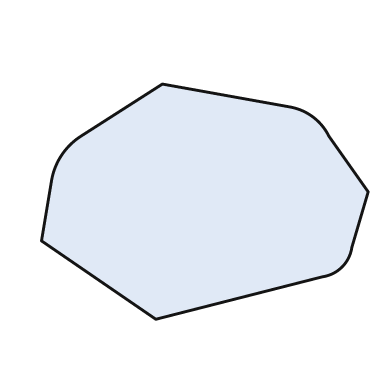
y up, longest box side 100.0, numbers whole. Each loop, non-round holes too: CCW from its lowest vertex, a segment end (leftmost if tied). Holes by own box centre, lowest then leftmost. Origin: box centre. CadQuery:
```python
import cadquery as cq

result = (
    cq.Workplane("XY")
    .moveTo(-15.0, -36.0)
    .lineTo(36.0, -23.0)
    .threePointArc((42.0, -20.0), (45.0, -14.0))
    .lineTo(50.0, 3.0)
    .lineTo(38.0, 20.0)
    .threePointArc((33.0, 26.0), (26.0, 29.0))
    .lineTo(-13.0, 36.0)
    .lineTo(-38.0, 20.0)
    .threePointArc((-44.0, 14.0), (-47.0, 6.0))
    .lineTo(-50.0, -12.0)
    .close()
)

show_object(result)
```